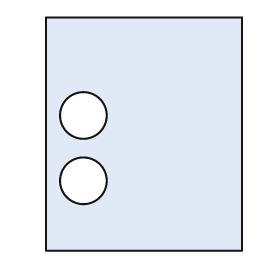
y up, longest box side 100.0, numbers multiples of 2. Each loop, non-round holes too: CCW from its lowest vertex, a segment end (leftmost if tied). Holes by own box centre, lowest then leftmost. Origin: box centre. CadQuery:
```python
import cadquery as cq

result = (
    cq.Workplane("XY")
    .moveTo(-42.0, -50.0)
    .lineTo(42.0, -50.0)
    .lineTo(42.0, 50.0)
    .lineTo(-42.0, 50.0)
    .close()
    .moveTo(-26.0, -20.0)
    .circle(10.0)
    .moveTo(-26.0, 8.0)
    .circle(10.0)
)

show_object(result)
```